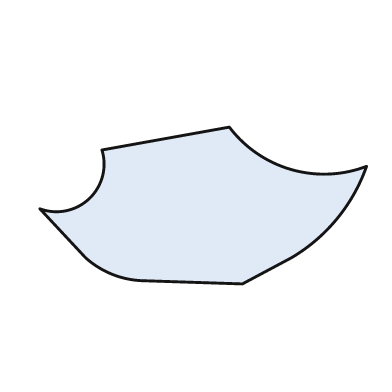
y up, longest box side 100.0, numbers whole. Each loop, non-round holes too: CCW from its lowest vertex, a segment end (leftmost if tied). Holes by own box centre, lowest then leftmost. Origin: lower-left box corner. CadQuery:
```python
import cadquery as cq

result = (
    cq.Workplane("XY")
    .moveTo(62.0, 0.0)
    .lineTo(77.0, 8.0)
    .threePointArc((91.0, 20.0), (100.0, 36.0))
    .threePointArc((77.0, 35.0), (58.0, 48.0))
    .lineTo(19.0, 41.0)
    .threePointArc((15.0, 26.0), (0.0, 23.0))
    .lineTo(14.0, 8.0)
    .threePointArc((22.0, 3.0), (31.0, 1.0))
    .close()
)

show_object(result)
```